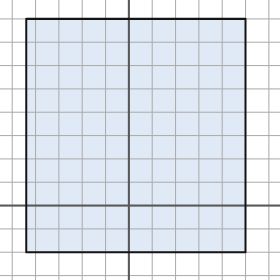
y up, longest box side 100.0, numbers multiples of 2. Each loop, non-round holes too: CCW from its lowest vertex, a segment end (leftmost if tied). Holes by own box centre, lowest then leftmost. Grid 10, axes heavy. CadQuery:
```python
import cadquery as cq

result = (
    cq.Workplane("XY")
    .moveTo(-44.0, -20.0)
    .lineTo(50.0, -20.0)
    .lineTo(50.0, 80.0)
    .lineTo(-44.0, 80.0)
    .close()
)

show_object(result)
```